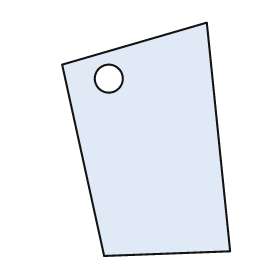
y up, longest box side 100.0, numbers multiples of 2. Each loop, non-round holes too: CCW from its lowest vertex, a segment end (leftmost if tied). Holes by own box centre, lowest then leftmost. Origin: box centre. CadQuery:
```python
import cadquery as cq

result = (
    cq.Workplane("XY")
    .moveTo(-18.0, -50.0)
    .lineTo(36.0, -48.0)
    .lineTo(26.0, 50.0)
    .lineTo(-36.0, 32.0)
    .close()
    .moveTo(-16.0, 26.0)
    .circle(6.0)
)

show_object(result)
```